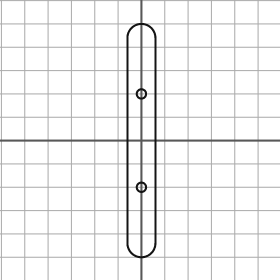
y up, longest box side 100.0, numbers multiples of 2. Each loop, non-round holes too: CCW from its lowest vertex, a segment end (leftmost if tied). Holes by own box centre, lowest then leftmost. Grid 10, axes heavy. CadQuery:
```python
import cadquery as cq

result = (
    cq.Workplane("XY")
    .moveTo(-6.0, -44.0)
    .threePointArc((0.0, -50.0), (6.0, -44.0))
    .lineTo(6.0, 44.0)
    .threePointArc((0.0, 50.0), (-6.0, 44.0))
    .close()
    .moveTo(0.0, -20.0)
    .circle(2.0)
    .moveTo(0.0, 20.0)
    .circle(2.0)
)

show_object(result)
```